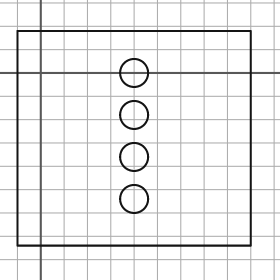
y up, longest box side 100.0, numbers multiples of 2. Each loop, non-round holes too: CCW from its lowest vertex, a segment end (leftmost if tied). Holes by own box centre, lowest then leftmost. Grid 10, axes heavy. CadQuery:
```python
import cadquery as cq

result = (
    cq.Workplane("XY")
    .moveTo(-10.0, -74.0)
    .lineTo(90.0, -74.0)
    .lineTo(90.0, 18.0)
    .lineTo(-10.0, 18.0)
    .close()
    .moveTo(40.0, -54.0)
    .circle(6.0)
    .moveTo(40.0, -36.0)
    .circle(6.0)
    .moveTo(40.0, -18.0)
    .circle(6.0)
    .moveTo(40.0, 0.0)
    .circle(6.0)
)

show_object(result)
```